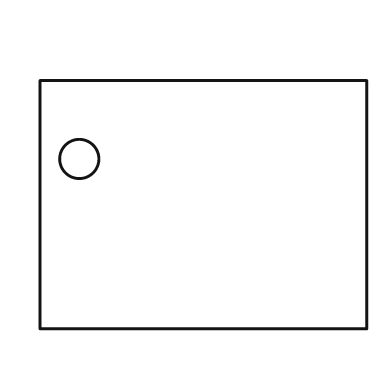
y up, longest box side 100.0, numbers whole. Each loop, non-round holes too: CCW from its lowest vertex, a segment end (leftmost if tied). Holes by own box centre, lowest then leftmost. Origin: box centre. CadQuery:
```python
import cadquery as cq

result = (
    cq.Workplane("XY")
    .moveTo(-50.0, -38.0)
    .lineTo(50.0, -38.0)
    .lineTo(50.0, 38.0)
    .lineTo(-50.0, 38.0)
    .close()
    .moveTo(-38.0, 14.0)
    .circle(6.0)
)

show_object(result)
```